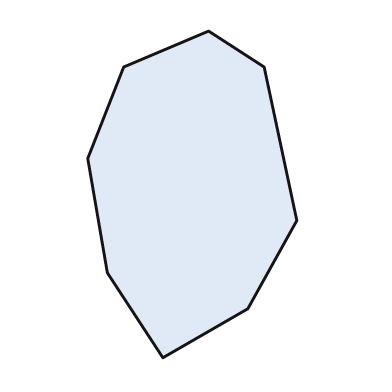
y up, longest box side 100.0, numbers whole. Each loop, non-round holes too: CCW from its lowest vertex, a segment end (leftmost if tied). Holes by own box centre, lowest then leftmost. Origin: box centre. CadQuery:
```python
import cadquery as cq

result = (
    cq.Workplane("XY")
    .moveTo(-9.0, -50.0)
    .lineTo(17.0, -35.0)
    .lineTo(32.0, -8.0)
    .lineTo(22.0, 39.0)
    .lineTo(5.0, 50.0)
    .lineTo(-21.0, 39.0)
    .lineTo(-32.0, 11.0)
    .lineTo(-26.0, -24.0)
    .close()
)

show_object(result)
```